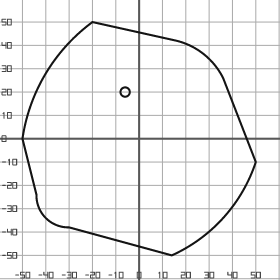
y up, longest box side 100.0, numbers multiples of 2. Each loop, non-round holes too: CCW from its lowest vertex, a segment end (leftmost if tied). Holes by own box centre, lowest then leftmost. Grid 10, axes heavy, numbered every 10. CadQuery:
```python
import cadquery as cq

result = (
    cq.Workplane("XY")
    .moveTo(14.0, -50.0)
    .threePointArc((36.0, -34.0), (50.0, -10.0))
    .lineTo(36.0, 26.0)
    .threePointArc((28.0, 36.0), (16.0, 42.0))
    .lineTo(-20.0, 50.0)
    .threePointArc((-40.0, 28.0), (-50.0, 0.0))
    .lineTo(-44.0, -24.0)
    .threePointArc((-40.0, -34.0), (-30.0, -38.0))
    .close()
    .moveTo(-6.0, 20.0)
    .circle(2.0)
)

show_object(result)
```